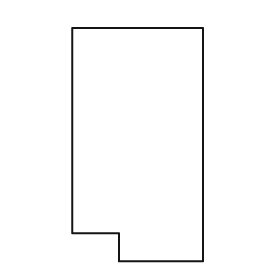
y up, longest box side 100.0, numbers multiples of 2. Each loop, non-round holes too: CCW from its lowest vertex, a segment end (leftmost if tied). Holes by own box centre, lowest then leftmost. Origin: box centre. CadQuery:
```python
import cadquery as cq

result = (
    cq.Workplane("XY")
    .moveTo(-8.0, -50.0)
    .lineTo(28.0, -50.0)
    .lineTo(28.0, 50.0)
    .lineTo(-28.0, 50.0)
    .lineTo(-28.0, -38.0)
    .lineTo(-8.0, -38.0)
    .close()
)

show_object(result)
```